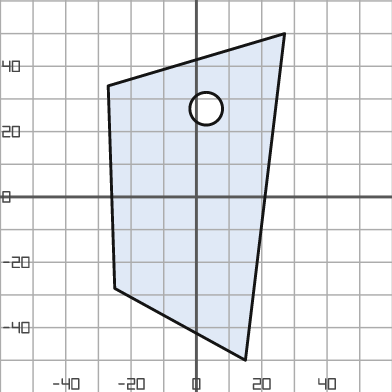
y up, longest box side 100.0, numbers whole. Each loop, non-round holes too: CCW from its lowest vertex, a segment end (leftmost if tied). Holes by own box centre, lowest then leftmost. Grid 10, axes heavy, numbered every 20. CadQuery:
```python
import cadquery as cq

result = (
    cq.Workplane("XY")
    .moveTo(15.0, -50.0)
    .lineTo(27.0, 50.0)
    .lineTo(-27.0, 34.0)
    .lineTo(-25.0, -28.0)
    .close()
    .moveTo(3.0, 27.0)
    .circle(5.0)
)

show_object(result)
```